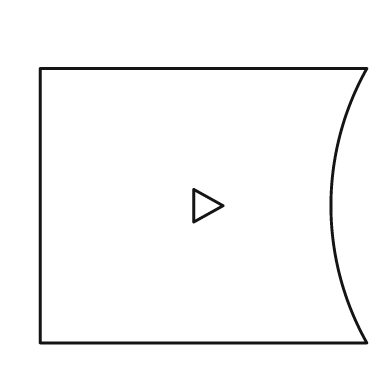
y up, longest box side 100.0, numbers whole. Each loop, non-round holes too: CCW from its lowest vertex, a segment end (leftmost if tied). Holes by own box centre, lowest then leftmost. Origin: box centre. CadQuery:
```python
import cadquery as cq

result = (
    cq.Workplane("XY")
    .moveTo(-50.0, -42.0)
    .lineTo(50.0, -42.0)
    .threePointArc((39.0, 0.0), (50.0, 42.0))
    .lineTo(-50.0, 42.0)
    .close()
    .moveTo(-3.0, -5.0)
    .lineTo(6.0, 0.0)
    .lineTo(-3.0, 5.0)
    .close()
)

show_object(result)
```